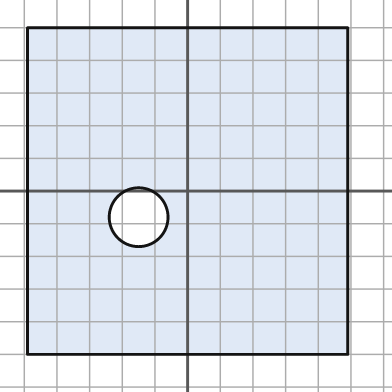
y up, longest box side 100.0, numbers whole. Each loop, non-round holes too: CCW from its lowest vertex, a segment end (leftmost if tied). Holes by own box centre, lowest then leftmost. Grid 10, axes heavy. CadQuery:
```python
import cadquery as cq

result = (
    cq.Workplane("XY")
    .moveTo(-49.0, -50.0)
    .lineTo(49.0, -50.0)
    .lineTo(49.0, 50.0)
    .lineTo(-49.0, 50.0)
    .close()
    .moveTo(-15.0, -8.0)
    .circle(9.0)
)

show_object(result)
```